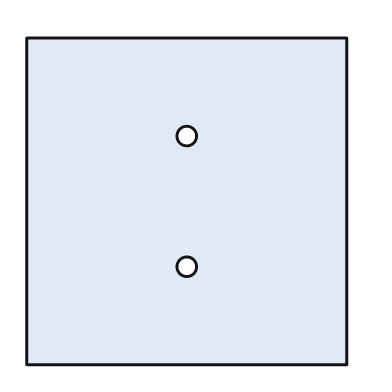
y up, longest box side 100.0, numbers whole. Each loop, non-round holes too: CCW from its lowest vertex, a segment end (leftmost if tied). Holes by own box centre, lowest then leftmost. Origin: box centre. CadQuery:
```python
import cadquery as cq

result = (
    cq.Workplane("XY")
    .moveTo(-49.0, -50.0)
    .lineTo(49.0, -50.0)
    .lineTo(49.0, 50.0)
    .lineTo(-49.0, 50.0)
    .close()
    .moveTo(0.0, -20.0)
    .circle(3.0)
    .moveTo(0.0, 20.0)
    .circle(3.0)
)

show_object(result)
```